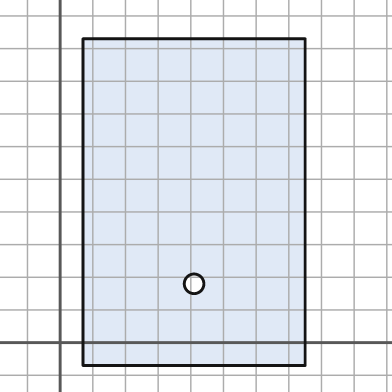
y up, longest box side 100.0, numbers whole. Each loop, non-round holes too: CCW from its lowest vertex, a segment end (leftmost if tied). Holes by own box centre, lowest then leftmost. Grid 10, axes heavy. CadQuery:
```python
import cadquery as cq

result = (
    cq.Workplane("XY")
    .moveTo(7.0, -7.0)
    .lineTo(75.0, -7.0)
    .lineTo(75.0, 93.0)
    .lineTo(7.0, 93.0)
    .close()
    .moveTo(41.0, 18.0)
    .circle(3.0)
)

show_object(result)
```